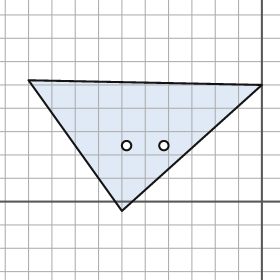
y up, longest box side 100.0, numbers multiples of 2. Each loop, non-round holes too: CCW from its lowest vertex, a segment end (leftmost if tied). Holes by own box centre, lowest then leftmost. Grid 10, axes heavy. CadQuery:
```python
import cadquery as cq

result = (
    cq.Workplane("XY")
    .moveTo(-60.0, -4.0)
    .lineTo(0.0, 50.0)
    .lineTo(-100.0, 52.0)
    .close()
    .moveTo(-58.0, 24.0)
    .circle(2.0)
    .moveTo(-42.0, 24.0)
    .circle(2.0)
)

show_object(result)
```